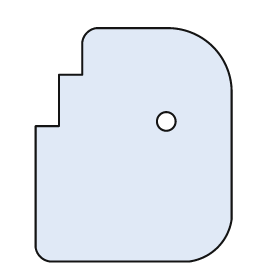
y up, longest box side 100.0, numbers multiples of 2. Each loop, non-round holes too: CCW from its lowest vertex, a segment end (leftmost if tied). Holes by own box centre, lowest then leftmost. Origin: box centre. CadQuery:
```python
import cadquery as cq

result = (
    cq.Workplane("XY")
    .moveTo(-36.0, -50.0)
    .lineTo(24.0, -50.0)
    .threePointArc((36.0, -44.0), (42.0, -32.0))
    .lineTo(42.0, 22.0)
    .threePointArc((34.0, 42.0), (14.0, 50.0))
    .lineTo(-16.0, 50.0)
    .threePointArc((-20.0, 48.0), (-22.0, 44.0))
    .lineTo(-22.0, 30.0)
    .lineTo(-32.0, 30.0)
    .lineTo(-32.0, 8.0)
    .lineTo(-42.0, 8.0)
    .lineTo(-42.0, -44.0)
    .threePointArc((-40.0, -48.0), (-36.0, -50.0))
    .close()
    .moveTo(14.0, 10.0)
    .circle(4.0)
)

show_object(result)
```